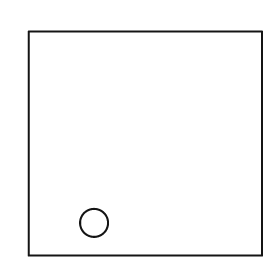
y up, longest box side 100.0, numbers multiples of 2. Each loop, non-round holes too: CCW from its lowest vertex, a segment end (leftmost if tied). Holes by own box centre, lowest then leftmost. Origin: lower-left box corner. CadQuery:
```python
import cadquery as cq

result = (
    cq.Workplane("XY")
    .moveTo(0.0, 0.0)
    .lineTo(100.0, 0.0)
    .lineTo(100.0, 96.0)
    .lineTo(0.0, 96.0)
    .close()
    .moveTo(28.0, 14.0)
    .circle(6.0)
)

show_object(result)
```